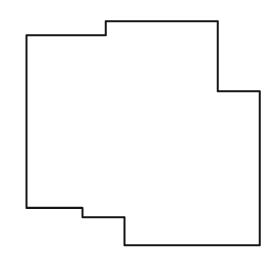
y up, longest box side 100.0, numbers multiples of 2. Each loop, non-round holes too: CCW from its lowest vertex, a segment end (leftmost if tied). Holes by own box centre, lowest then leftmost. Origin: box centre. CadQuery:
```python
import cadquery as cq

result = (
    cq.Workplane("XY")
    .moveTo(-8.0, -48.0)
    .lineTo(50.0, -48.0)
    .lineTo(50.0, 18.0)
    .lineTo(32.0, 18.0)
    .lineTo(32.0, 48.0)
    .lineTo(-16.0, 48.0)
    .lineTo(-16.0, 42.0)
    .lineTo(-50.0, 42.0)
    .lineTo(-50.0, -32.0)
    .lineTo(-26.0, -32.0)
    .lineTo(-26.0, -36.0)
    .lineTo(-8.0, -36.0)
    .close()
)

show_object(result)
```